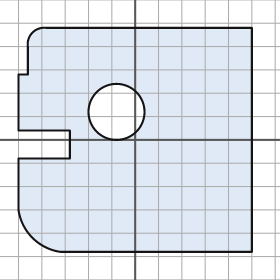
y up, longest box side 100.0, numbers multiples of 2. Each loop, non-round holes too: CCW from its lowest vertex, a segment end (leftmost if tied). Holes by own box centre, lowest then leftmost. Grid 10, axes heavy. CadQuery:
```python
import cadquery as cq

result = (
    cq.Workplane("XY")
    .moveTo(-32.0, -48.0)
    .lineTo(50.0, -48.0)
    .lineTo(50.0, 48.0)
    .lineTo(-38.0, 48.0)
    .threePointArc((-44.0, 46.0), (-46.0, 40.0))
    .lineTo(-46.0, 28.0)
    .lineTo(-50.0, 28.0)
    .lineTo(-50.0, 4.0)
    .lineTo(-28.0, 4.0)
    .lineTo(-28.0, -8.0)
    .lineTo(-50.0, -8.0)
    .lineTo(-50.0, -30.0)
    .threePointArc((-44.0, -42.0), (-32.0, -48.0))
    .close()
    .moveTo(-8.0, 12.0)
    .circle(12.0)
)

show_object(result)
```